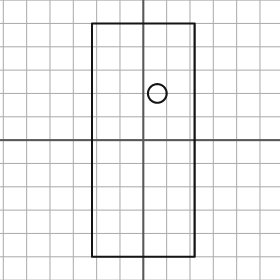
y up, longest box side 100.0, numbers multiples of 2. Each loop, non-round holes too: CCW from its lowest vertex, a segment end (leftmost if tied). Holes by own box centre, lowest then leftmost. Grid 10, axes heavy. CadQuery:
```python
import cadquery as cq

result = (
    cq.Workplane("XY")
    .moveTo(-22.0, -50.0)
    .lineTo(22.0, -50.0)
    .lineTo(22.0, 50.0)
    .lineTo(-22.0, 50.0)
    .close()
    .moveTo(6.0, 20.0)
    .circle(4.0)
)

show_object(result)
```